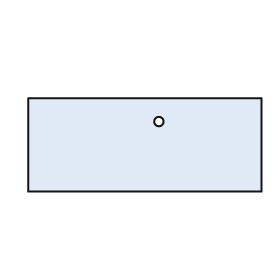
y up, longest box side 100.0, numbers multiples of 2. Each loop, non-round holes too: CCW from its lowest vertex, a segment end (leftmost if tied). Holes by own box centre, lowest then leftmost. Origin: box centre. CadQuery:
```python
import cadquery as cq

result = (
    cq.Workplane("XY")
    .moveTo(-50.0, -20.0)
    .lineTo(50.0, -20.0)
    .lineTo(50.0, 20.0)
    .lineTo(-50.0, 20.0)
    .close()
    .moveTo(6.0, 10.0)
    .circle(2.0)
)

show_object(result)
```